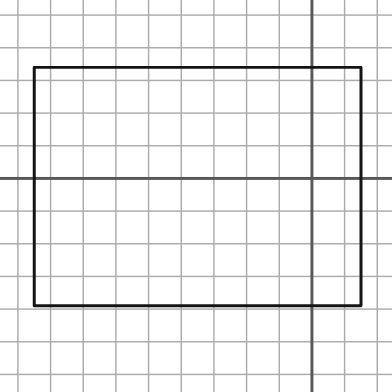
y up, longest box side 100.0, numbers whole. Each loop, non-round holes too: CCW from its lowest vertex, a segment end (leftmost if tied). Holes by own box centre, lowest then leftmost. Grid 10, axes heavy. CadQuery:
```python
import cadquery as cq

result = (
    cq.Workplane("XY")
    .moveTo(-85.0, -39.0)
    .lineTo(15.0, -39.0)
    .lineTo(15.0, 34.0)
    .lineTo(-85.0, 34.0)
    .close()
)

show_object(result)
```